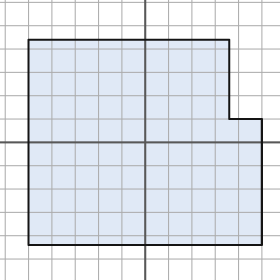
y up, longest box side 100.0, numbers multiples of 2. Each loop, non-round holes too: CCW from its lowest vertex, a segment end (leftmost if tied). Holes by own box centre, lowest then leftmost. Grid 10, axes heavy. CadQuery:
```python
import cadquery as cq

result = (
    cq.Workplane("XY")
    .moveTo(-50.0, -44.0)
    .lineTo(50.0, -44.0)
    .lineTo(50.0, 10.0)
    .lineTo(36.0, 10.0)
    .lineTo(36.0, 44.0)
    .lineTo(-50.0, 44.0)
    .close()
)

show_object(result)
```